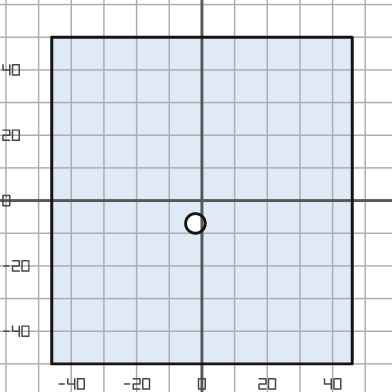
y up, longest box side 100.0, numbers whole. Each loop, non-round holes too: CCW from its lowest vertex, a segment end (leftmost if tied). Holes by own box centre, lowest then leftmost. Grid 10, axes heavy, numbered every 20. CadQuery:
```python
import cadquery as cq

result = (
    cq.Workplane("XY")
    .moveTo(-46.0, -50.0)
    .lineTo(46.0, -50.0)
    .lineTo(46.0, 50.0)
    .lineTo(-46.0, 50.0)
    .close()
    .moveTo(-2.0, -7.0)
    .circle(3.0)
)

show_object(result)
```